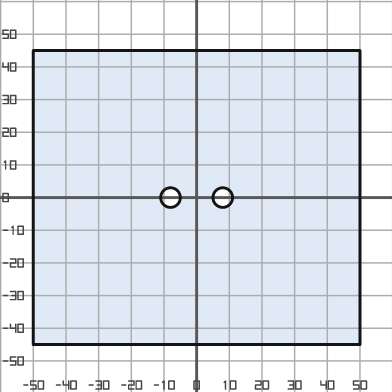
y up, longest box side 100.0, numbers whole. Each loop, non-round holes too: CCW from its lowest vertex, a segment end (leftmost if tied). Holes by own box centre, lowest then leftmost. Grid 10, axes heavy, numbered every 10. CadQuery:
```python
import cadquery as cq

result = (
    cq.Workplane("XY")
    .moveTo(-50.0, -45.0)
    .lineTo(50.0, -45.0)
    .lineTo(50.0, 45.0)
    .lineTo(-50.0, 45.0)
    .close()
    .moveTo(-8.0, 0.0)
    .circle(3.0)
    .moveTo(8.0, 0.0)
    .circle(3.0)
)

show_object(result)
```